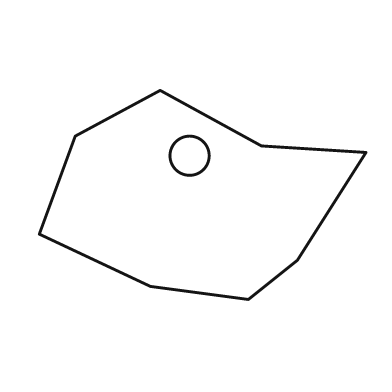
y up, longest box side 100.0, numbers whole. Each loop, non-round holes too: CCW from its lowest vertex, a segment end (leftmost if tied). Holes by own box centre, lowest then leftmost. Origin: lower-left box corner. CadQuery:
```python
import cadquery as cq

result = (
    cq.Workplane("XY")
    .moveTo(64.0, 0.0)
    .lineTo(79.0, 12.0)
    .lineTo(100.0, 45.0)
    .lineTo(68.0, 47.0)
    .lineTo(37.0, 64.0)
    .lineTo(11.0, 50.0)
    .lineTo(0.0, 20.0)
    .lineTo(34.0, 4.0)
    .close()
    .moveTo(46.0, 44.0)
    .circle(6.0)
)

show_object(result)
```